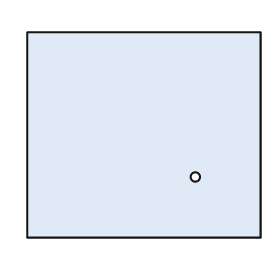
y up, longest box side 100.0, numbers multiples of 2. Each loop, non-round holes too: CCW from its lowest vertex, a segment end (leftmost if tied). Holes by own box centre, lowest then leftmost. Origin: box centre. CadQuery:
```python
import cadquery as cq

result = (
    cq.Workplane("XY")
    .moveTo(-50.0, -44.0)
    .lineTo(50.0, -44.0)
    .lineTo(50.0, 44.0)
    .lineTo(-50.0, 44.0)
    .close()
    .moveTo(22.0, -18.0)
    .circle(2.0)
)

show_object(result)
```